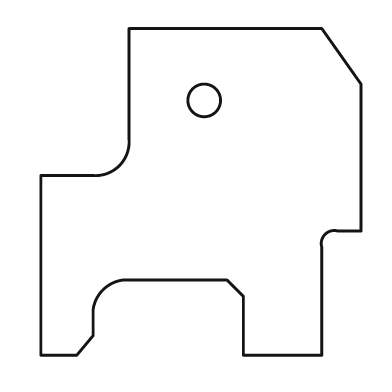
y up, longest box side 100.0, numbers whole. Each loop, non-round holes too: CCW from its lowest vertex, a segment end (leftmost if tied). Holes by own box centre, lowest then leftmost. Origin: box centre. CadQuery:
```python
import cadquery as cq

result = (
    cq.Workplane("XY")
    .moveTo(-49.0, -50.0)
    .lineTo(-38.0, -50.0)
    .lineTo(-33.0, -44.0)
    .lineTo(-33.0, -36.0)
    .threePointArc((-30.0, -30.0), (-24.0, -27.0))
    .lineTo(8.0, -27.0)
    .lineTo(13.0, -32.0)
    .lineTo(13.0, -50.0)
    .lineTo(37.0, -50.0)
    .lineTo(37.0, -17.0)
    .threePointArc((38.0, -13.0), (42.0, -12.0))
    .lineTo(49.0, -12.0)
    .lineTo(49.0, 33.0)
    .lineTo(37.0, 50.0)
    .lineTo(-22.0, 50.0)
    .lineTo(-22.0, 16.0)
    .threePointArc((-25.0, 8.0), (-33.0, 5.0))
    .lineTo(-49.0, 5.0)
    .close()
    .moveTo(1.0, 28.0)
    .circle(5.0)
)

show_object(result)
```